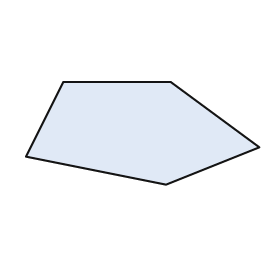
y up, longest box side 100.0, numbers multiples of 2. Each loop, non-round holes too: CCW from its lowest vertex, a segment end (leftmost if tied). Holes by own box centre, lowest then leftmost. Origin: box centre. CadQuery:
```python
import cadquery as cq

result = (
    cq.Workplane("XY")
    .moveTo(10.0, -22.0)
    .lineTo(50.0, -6.0)
    .lineTo(12.0, 22.0)
    .lineTo(-34.0, 22.0)
    .lineTo(-50.0, -10.0)
    .close()
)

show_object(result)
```